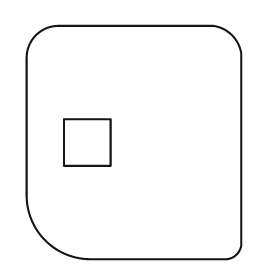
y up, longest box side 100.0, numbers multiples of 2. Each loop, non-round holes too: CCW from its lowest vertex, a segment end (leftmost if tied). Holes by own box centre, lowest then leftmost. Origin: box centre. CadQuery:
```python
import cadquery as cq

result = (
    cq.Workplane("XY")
    .moveTo(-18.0, -50.0)
    .lineTo(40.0, -50.0)
    .threePointArc((44.0, -48.0), (46.0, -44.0))
    .lineTo(46.0, 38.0)
    .threePointArc((42.0, 46.0), (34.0, 50.0))
    .lineTo(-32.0, 50.0)
    .threePointArc((-42.0, 46.0), (-46.0, 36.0))
    .lineTo(-46.0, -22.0)
    .threePointArc((-38.0, -42.0), (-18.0, -50.0))
    .close()
    .moveTo(-30.0, -10.0)
    .lineTo(-10.0, -10.0)
    .lineTo(-10.0, 10.0)
    .lineTo(-30.0, 10.0)
    .close()
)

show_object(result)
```